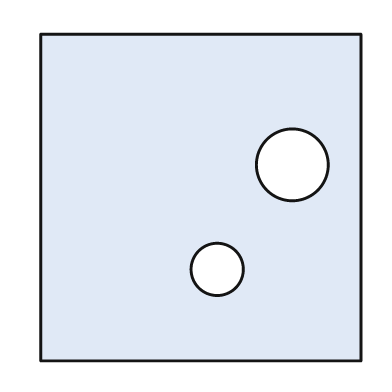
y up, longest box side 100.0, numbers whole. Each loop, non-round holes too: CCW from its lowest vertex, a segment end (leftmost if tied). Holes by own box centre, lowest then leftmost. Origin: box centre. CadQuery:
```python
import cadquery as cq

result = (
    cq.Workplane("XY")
    .moveTo(-49.0, -50.0)
    .lineTo(49.0, -50.0)
    .lineTo(49.0, 50.0)
    .lineTo(-49.0, 50.0)
    .close()
    .moveTo(5.0, -22.0)
    .circle(8.0)
    .moveTo(28.0, 10.0)
    .circle(11.0)
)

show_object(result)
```